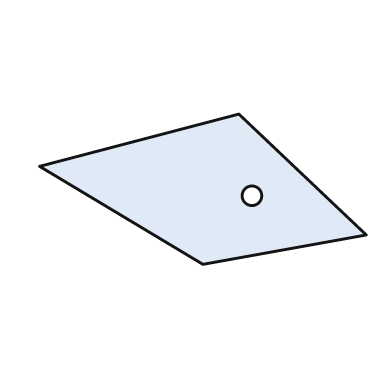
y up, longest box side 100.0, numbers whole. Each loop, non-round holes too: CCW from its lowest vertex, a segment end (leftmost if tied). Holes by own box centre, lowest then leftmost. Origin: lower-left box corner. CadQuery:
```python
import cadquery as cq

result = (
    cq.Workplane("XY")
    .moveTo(50.0, 0.0)
    .lineTo(100.0, 9.0)
    .lineTo(61.0, 46.0)
    .lineTo(0.0, 30.0)
    .close()
    .moveTo(65.0, 21.0)
    .circle(3.0)
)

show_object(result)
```